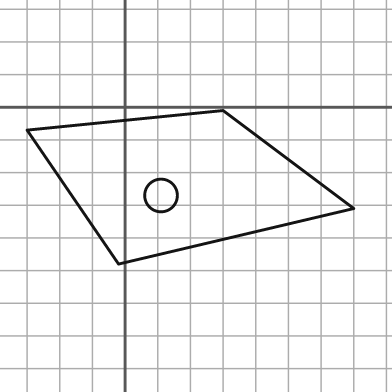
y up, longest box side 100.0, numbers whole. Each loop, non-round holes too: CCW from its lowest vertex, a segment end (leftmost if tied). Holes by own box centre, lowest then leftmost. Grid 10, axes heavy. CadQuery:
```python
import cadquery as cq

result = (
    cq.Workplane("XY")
    .moveTo(-2.0, -48.0)
    .lineTo(70.0, -31.0)
    .lineTo(30.0, -1.0)
    .lineTo(-30.0, -7.0)
    .close()
    .moveTo(11.0, -27.0)
    .circle(5.0)
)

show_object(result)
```